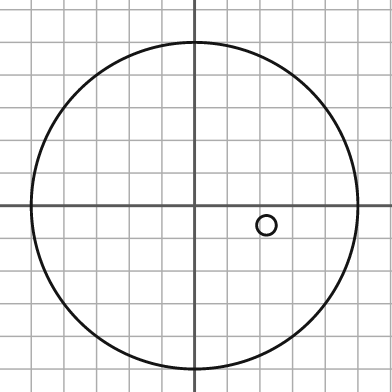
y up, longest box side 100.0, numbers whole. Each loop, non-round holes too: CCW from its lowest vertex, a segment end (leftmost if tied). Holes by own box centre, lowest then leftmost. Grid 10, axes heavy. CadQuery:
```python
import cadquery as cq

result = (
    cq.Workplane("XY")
    .moveTo(0.0, 0.0)
    .circle(50.0)
    .moveTo(22.0, -6.0)
    .circle(3.0)
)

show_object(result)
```